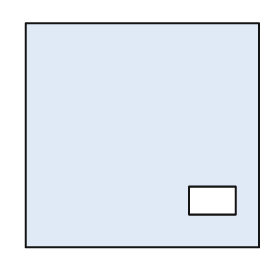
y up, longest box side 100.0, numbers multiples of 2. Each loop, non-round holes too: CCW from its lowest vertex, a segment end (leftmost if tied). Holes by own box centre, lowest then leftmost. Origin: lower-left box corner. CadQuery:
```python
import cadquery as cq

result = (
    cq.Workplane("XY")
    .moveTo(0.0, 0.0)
    .lineTo(100.0, 0.0)
    .lineTo(100.0, 96.0)
    .lineTo(0.0, 96.0)
    .close()
    .moveTo(70.0, 14.0)
    .lineTo(90.0, 14.0)
    .lineTo(90.0, 26.0)
    .lineTo(70.0, 26.0)
    .close()
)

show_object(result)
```